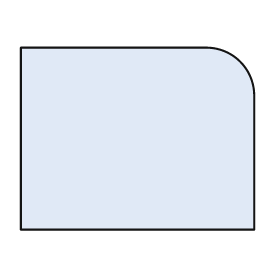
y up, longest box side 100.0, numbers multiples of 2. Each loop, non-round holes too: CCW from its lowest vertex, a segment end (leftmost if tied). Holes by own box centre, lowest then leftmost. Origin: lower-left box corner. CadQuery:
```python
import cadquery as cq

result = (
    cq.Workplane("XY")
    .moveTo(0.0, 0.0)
    .lineTo(100.0, 0.0)
    .lineTo(100.0, 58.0)
    .threePointArc((94.0, 72.0), (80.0, 78.0))
    .lineTo(0.0, 78.0)
    .close()
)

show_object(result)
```